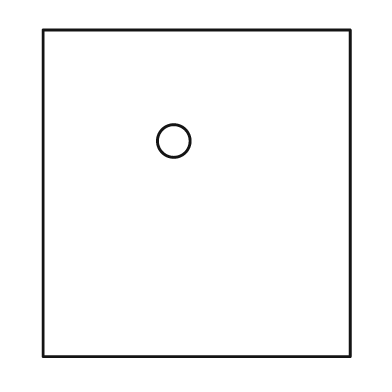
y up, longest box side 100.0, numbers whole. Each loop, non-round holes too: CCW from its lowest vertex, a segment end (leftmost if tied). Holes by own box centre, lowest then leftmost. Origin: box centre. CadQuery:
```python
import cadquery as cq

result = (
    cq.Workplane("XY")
    .moveTo(-47.0, -50.0)
    .lineTo(47.0, -50.0)
    .lineTo(47.0, 50.0)
    .lineTo(-47.0, 50.0)
    .close()
    .moveTo(-7.0, 16.0)
    .circle(5.0)
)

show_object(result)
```